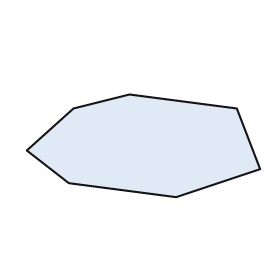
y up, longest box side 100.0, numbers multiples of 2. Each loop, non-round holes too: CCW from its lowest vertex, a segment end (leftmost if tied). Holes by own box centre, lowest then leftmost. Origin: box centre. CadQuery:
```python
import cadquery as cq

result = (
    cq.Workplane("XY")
    .moveTo(14.0, -22.0)
    .lineTo(50.0, -10.0)
    .lineTo(40.0, 16.0)
    .lineTo(-6.0, 22.0)
    .lineTo(-30.0, 16.0)
    .lineTo(-50.0, -2.0)
    .lineTo(-32.0, -16.0)
    .close()
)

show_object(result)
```